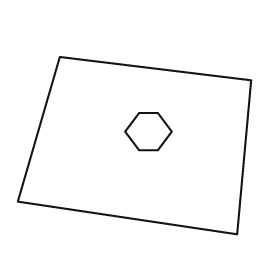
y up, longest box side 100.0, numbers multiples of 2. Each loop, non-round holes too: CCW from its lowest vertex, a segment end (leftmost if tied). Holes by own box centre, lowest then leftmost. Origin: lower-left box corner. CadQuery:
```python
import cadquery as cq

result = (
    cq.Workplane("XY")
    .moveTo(94.0, 0.0)
    .lineTo(100.0, 66.0)
    .lineTo(18.0, 76.0)
    .lineTo(0.0, 14.0)
    .close()
    .moveTo(52.0, 36.0)
    .lineTo(60.0, 36.0)
    .lineTo(66.0, 44.0)
    .lineTo(60.0, 52.0)
    .lineTo(52.0, 52.0)
    .lineTo(46.0, 44.0)
    .close()
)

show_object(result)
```